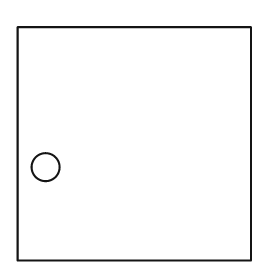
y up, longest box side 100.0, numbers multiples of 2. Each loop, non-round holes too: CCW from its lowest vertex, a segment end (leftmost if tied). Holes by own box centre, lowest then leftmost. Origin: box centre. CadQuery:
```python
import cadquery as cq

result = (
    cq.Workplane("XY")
    .moveTo(-50.0, -50.0)
    .lineTo(50.0, -50.0)
    .lineTo(50.0, 50.0)
    .lineTo(-50.0, 50.0)
    .close()
    .moveTo(-38.0, -10.0)
    .circle(6.0)
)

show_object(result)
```